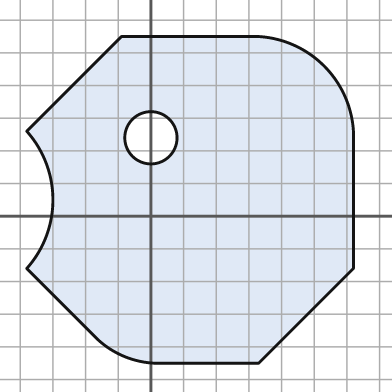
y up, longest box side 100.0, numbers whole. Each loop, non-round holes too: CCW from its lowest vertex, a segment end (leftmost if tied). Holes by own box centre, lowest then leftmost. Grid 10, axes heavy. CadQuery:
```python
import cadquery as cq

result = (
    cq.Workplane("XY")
    .moveTo(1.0, -45.0)
    .lineTo(33.0, -45.0)
    .lineTo(62.0, -16.0)
    .lineTo(62.0, 26.0)
    .threePointArc((53.0, 46.0), (33.0, 55.0))
    .lineTo(-9.0, 55.0)
    .lineTo(-38.0, 26.0)
    .threePointArc((-30.0, 5.0), (-38.0, -16.0))
    .lineTo(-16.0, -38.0)
    .threePointArc((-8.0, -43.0), (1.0, -45.0))
    .close()
    .moveTo(0.0, 24.0)
    .circle(8.0)
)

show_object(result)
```